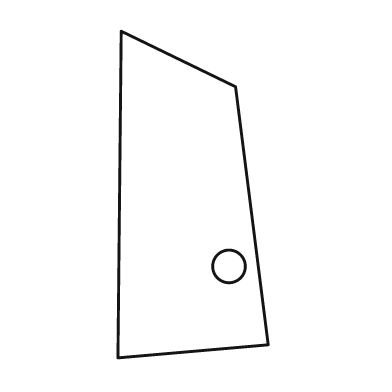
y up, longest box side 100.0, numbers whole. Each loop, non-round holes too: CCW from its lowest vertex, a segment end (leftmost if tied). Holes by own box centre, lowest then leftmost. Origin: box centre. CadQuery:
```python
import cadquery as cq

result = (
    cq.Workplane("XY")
    .moveTo(-23.0, -50.0)
    .lineTo(23.0, -46.0)
    .lineTo(13.0, 33.0)
    .lineTo(-22.0, 50.0)
    .close()
    .moveTo(11.0, -22.0)
    .circle(5.0)
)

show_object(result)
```